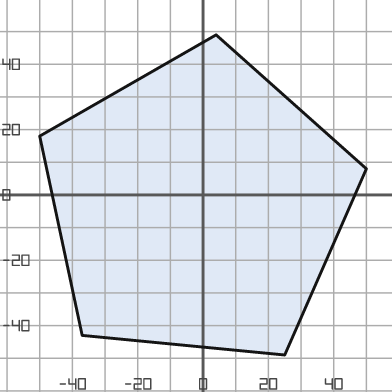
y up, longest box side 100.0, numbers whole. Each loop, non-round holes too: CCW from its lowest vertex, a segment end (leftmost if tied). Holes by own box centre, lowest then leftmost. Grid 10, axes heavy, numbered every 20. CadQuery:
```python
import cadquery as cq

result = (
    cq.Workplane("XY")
    .moveTo(25.0, -49.0)
    .lineTo(50.0, 8.0)
    .lineTo(4.0, 49.0)
    .lineTo(-50.0, 18.0)
    .lineTo(-37.0, -43.0)
    .close()
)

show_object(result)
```